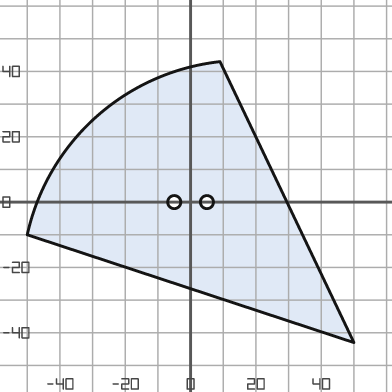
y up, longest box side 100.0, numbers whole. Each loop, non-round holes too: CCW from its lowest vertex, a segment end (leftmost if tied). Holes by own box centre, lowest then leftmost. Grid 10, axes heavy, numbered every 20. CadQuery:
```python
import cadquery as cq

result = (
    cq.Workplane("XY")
    .moveTo(50.0, -43.0)
    .lineTo(9.0, 43.0)
    .threePointArc((-29.0, 26.0), (-50.0, -10.0))
    .close()
    .moveTo(-5.0, 0.0)
    .circle(2.0)
    .moveTo(5.0, 0.0)
    .circle(2.0)
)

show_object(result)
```